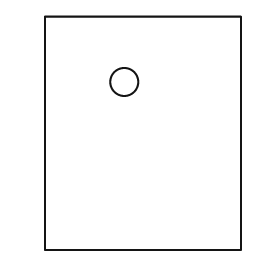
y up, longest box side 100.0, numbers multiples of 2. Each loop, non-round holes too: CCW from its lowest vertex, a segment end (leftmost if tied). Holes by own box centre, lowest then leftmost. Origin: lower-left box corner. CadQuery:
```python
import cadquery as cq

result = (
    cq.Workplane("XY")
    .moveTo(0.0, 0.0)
    .lineTo(84.0, 0.0)
    .lineTo(84.0, 100.0)
    .lineTo(0.0, 100.0)
    .close()
    .moveTo(34.0, 72.0)
    .circle(6.0)
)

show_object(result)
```